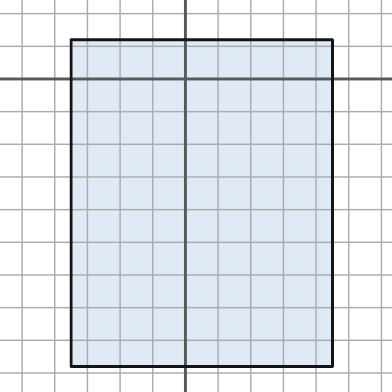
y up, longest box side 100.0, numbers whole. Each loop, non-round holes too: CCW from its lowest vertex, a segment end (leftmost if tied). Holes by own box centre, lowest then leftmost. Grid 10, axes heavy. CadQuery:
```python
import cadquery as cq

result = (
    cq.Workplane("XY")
    .moveTo(-35.0, -88.0)
    .lineTo(45.0, -88.0)
    .lineTo(45.0, 12.0)
    .lineTo(-35.0, 12.0)
    .close()
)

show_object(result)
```